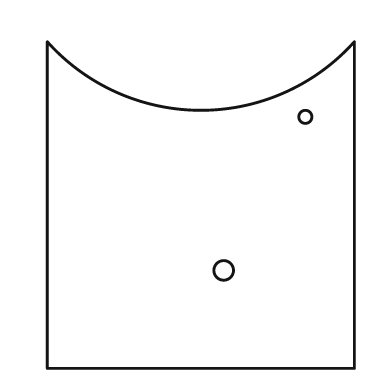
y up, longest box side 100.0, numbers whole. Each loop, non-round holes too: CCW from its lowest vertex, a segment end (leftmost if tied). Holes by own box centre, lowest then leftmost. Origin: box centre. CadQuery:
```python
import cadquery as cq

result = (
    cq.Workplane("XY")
    .moveTo(-47.0, -50.0)
    .lineTo(47.0, -50.0)
    .lineTo(47.0, 50.0)
    .threePointArc((0.0, 29.0), (-47.0, 50.0))
    .close()
    .moveTo(7.0, -20.0)
    .circle(3.0)
    .moveTo(32.0, 27.0)
    .circle(2.0)
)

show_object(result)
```